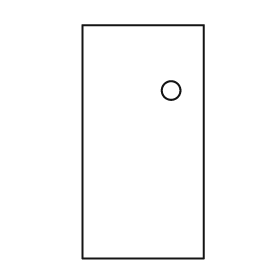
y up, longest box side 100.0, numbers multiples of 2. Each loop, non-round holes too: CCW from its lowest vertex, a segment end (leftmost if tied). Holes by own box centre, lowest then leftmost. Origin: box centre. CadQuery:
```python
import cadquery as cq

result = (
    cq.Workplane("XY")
    .moveTo(-26.0, -50.0)
    .lineTo(26.0, -50.0)
    .lineTo(26.0, 50.0)
    .lineTo(-26.0, 50.0)
    .close()
    .moveTo(12.0, 22.0)
    .circle(4.0)
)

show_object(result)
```